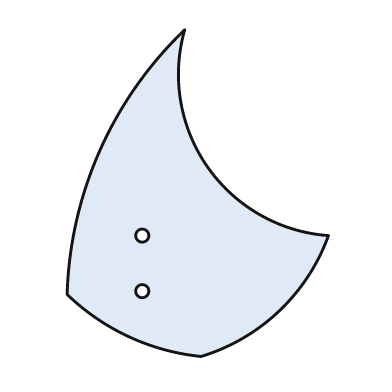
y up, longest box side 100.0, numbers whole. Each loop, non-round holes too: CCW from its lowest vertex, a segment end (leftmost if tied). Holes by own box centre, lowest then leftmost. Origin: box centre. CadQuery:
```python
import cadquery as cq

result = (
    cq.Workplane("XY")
    .moveTo(1.0, -50.0)
    .threePointArc((25.0, -36.0), (40.0, -13.0))
    .threePointArc((3.0, 8.0), (-4.0, 50.0))
    .threePointArc((-30.0, 13.0), (-40.0, -31.0))
    .threePointArc((-21.0, -44.0), (1.0, -50.0))
    .close()
    .moveTo(-17.0, -30.0)
    .circle(2.0)
    .moveTo(-17.0, -13.0)
    .circle(2.0)
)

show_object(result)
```